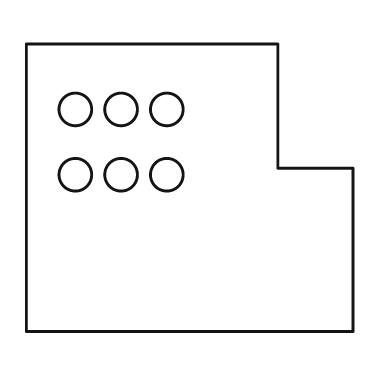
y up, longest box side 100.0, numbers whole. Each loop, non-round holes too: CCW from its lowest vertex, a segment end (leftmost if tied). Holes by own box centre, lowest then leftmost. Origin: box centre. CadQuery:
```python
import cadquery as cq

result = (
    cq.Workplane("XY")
    .moveTo(-50.0, -44.0)
    .lineTo(50.0, -44.0)
    .lineTo(50.0, 6.0)
    .lineTo(27.0, 6.0)
    .lineTo(27.0, 44.0)
    .lineTo(-50.0, 44.0)
    .close()
    .moveTo(-35.0, 4.0)
    .circle(5.0)
    .moveTo(-21.0, 4.0)
    .circle(5.0)
    .moveTo(-7.0, 4.0)
    .circle(5.0)
    .moveTo(-35.0, 24.0)
    .circle(5.0)
    .moveTo(-21.0, 24.0)
    .circle(5.0)
    .moveTo(-7.0, 24.0)
    .circle(5.0)
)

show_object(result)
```